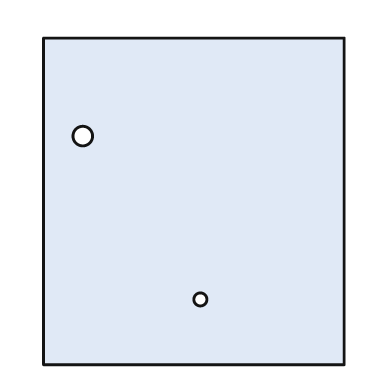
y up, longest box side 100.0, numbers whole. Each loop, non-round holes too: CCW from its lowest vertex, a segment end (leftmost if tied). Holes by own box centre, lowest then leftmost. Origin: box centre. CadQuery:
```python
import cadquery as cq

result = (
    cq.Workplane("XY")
    .moveTo(-46.0, -50.0)
    .lineTo(46.0, -50.0)
    .lineTo(46.0, 50.0)
    .lineTo(-46.0, 50.0)
    .close()
    .moveTo(2.0, -30.0)
    .circle(2.0)
    .moveTo(-34.0, 20.0)
    .circle(3.0)
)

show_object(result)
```